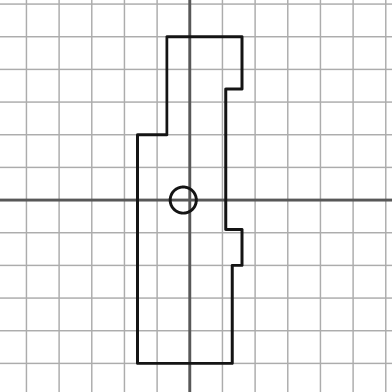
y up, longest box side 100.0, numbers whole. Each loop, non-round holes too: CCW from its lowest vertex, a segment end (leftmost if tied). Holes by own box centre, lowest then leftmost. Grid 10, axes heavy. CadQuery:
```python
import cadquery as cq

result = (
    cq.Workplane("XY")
    .moveTo(-16.0, -50.0)
    .lineTo(13.0, -50.0)
    .lineTo(13.0, -20.0)
    .lineTo(16.0, -20.0)
    .lineTo(16.0, -9.0)
    .lineTo(11.0, -9.0)
    .lineTo(11.0, 34.0)
    .lineTo(16.0, 34.0)
    .lineTo(16.0, 50.0)
    .lineTo(-7.0, 50.0)
    .lineTo(-7.0, 20.0)
    .lineTo(-16.0, 20.0)
    .close()
    .moveTo(-2.0, 0.0)
    .circle(4.0)
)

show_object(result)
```